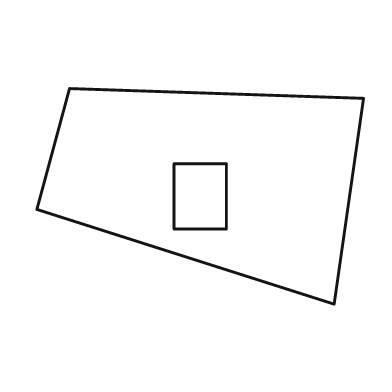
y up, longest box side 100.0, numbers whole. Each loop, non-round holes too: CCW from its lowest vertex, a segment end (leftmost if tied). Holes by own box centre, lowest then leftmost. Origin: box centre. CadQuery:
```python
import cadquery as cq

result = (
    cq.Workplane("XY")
    .moveTo(41.0, -33.0)
    .lineTo(50.0, 30.0)
    .lineTo(-40.0, 33.0)
    .lineTo(-50.0, -4.0)
    .close()
    .moveTo(-8.0, -10.0)
    .lineTo(8.0, -10.0)
    .lineTo(8.0, 10.0)
    .lineTo(-8.0, 10.0)
    .close()
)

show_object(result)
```